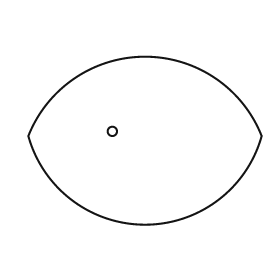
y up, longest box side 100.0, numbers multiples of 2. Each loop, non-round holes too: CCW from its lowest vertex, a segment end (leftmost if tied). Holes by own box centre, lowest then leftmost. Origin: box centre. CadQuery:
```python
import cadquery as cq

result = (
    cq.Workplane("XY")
    .moveTo(-50.0, 2.0)
    .threePointArc((0.0, -36.0), (50.0, 2.0))
    .threePointArc((0.0, 36.0), (-50.0, 2.0))
    .close()
    .moveTo(-14.0, 4.0)
    .circle(2.0)
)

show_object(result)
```